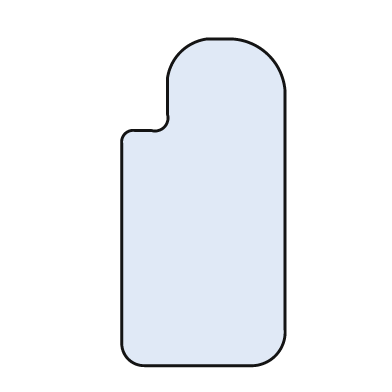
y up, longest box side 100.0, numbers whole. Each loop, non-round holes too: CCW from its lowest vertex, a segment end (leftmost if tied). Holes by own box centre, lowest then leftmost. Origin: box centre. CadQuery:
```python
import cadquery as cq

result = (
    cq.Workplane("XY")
    .moveTo(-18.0, -50.0)
    .lineTo(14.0, -50.0)
    .threePointArc((22.0, -47.0), (25.0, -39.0))
    .lineTo(25.0, 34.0)
    .threePointArc((20.0, 45.0), (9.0, 50.0))
    .lineTo(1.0, 50.0)
    .threePointArc((-7.0, 46.0), (-11.0, 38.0))
    .lineTo(-11.0, 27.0)
    .threePointArc((-12.0, 23.0), (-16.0, 22.0))
    .lineTo(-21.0, 22.0)
    .threePointArc((-24.0, 21.0), (-25.0, 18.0))
    .lineTo(-25.0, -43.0)
    .threePointArc((-23.0, -48.0), (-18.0, -50.0))
    .close()
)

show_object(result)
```